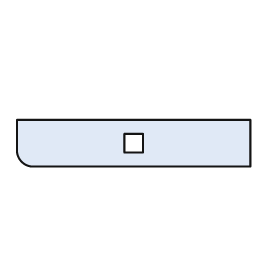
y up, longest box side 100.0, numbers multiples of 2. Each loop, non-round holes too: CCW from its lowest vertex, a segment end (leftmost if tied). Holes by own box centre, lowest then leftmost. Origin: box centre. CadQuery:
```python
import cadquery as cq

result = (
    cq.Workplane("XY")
    .moveTo(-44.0, -10.0)
    .lineTo(50.0, -10.0)
    .lineTo(50.0, 10.0)
    .lineTo(-50.0, 10.0)
    .lineTo(-50.0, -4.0)
    .threePointArc((-48.0, -8.0), (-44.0, -10.0))
    .close()
    .moveTo(-4.0, -4.0)
    .lineTo(4.0, -4.0)
    .lineTo(4.0, 4.0)
    .lineTo(-4.0, 4.0)
    .close()
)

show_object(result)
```